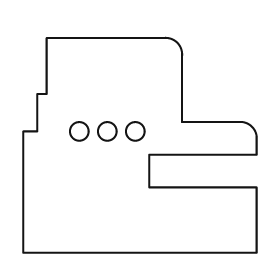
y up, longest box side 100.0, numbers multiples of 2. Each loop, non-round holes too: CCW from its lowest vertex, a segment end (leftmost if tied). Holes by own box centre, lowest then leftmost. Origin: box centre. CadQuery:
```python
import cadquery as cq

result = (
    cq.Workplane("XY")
    .moveTo(-50.0, -46.0)
    .lineTo(50.0, -46.0)
    .lineTo(50.0, -18.0)
    .lineTo(4.0, -18.0)
    .lineTo(4.0, -4.0)
    .lineTo(50.0, -4.0)
    .lineTo(50.0, 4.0)
    .threePointArc((48.0, 8.0), (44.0, 10.0))
    .lineTo(18.0, 10.0)
    .lineTo(18.0, 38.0)
    .threePointArc((16.0, 44.0), (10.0, 46.0))
    .lineTo(-40.0, 46.0)
    .lineTo(-40.0, 22.0)
    .lineTo(-44.0, 22.0)
    .lineTo(-44.0, 6.0)
    .lineTo(-50.0, 6.0)
    .close()
    .moveTo(-26.0, 6.0)
    .circle(4.0)
    .moveTo(-14.0, 6.0)
    .circle(4.0)
    .moveTo(-2.0, 6.0)
    .circle(4.0)
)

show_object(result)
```